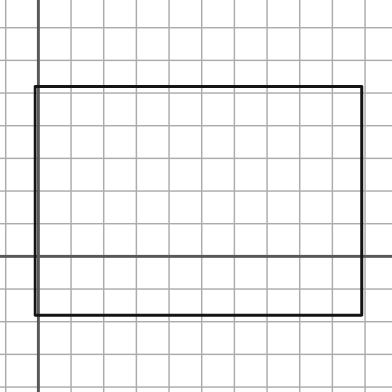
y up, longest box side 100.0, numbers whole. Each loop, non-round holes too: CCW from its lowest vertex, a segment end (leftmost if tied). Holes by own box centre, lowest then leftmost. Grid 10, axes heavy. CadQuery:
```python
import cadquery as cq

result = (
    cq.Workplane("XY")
    .moveTo(-1.0, -18.0)
    .lineTo(99.0, -18.0)
    .lineTo(99.0, 52.0)
    .lineTo(-1.0, 52.0)
    .close()
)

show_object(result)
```